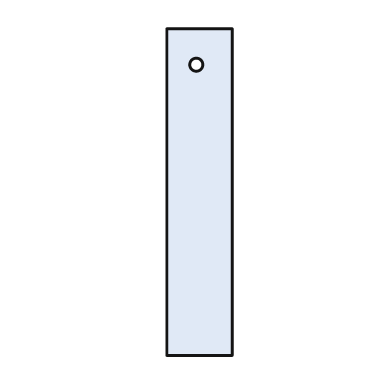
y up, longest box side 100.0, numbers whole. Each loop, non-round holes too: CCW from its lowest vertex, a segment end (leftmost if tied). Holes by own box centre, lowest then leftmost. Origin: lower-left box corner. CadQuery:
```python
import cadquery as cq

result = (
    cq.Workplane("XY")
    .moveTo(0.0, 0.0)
    .lineTo(20.0, 0.0)
    .lineTo(20.0, 100.0)
    .lineTo(0.0, 100.0)
    .close()
    .moveTo(9.0, 89.0)
    .circle(2.0)
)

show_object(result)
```